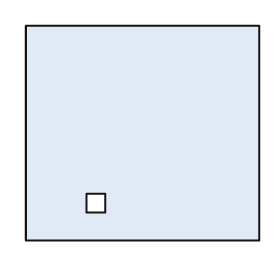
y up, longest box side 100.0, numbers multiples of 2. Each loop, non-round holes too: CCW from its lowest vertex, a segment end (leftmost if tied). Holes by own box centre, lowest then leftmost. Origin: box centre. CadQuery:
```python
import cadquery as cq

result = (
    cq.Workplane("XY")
    .moveTo(-50.0, -46.0)
    .lineTo(50.0, -46.0)
    .lineTo(50.0, 46.0)
    .lineTo(-50.0, 46.0)
    .close()
    .moveTo(-24.0, -34.0)
    .lineTo(-16.0, -34.0)
    .lineTo(-16.0, -26.0)
    .lineTo(-24.0, -26.0)
    .close()
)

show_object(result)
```